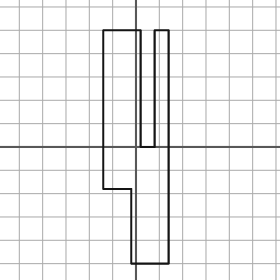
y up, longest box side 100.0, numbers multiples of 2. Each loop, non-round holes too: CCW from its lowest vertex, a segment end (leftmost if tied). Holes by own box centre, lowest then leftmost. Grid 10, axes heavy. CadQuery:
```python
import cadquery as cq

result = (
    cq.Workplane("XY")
    .moveTo(-2.0, -50.0)
    .lineTo(14.0, -50.0)
    .lineTo(14.0, 50.0)
    .lineTo(8.0, 50.0)
    .lineTo(8.0, 0.0)
    .lineTo(2.0, 0.0)
    .lineTo(2.0, 50.0)
    .lineTo(-14.0, 50.0)
    .lineTo(-14.0, -18.0)
    .lineTo(-2.0, -18.0)
    .close()
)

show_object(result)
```